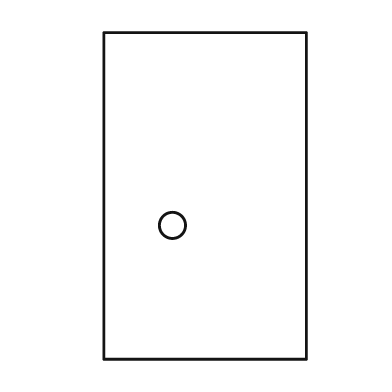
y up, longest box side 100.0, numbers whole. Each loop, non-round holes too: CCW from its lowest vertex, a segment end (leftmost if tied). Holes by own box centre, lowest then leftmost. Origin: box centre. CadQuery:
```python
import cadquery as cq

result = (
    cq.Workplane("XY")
    .moveTo(-31.0, -50.0)
    .lineTo(31.0, -50.0)
    .lineTo(31.0, 50.0)
    .lineTo(-31.0, 50.0)
    .close()
    .moveTo(-10.0, -9.0)
    .circle(4.0)
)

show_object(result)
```